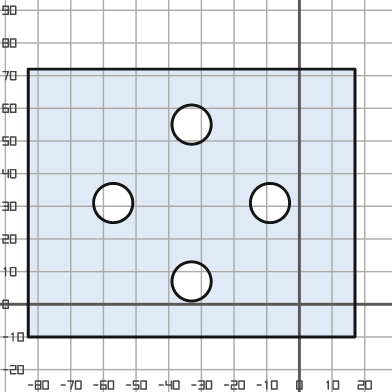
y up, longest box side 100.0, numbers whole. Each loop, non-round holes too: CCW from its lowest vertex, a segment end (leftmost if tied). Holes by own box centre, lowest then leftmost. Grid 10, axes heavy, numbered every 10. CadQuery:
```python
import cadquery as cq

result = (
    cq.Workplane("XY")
    .moveTo(-83.0, -10.0)
    .lineTo(17.0, -10.0)
    .lineTo(17.0, 72.0)
    .lineTo(-83.0, 72.0)
    .close()
    .moveTo(-33.0, 7.0)
    .circle(6.0)
    .moveTo(-57.0, 31.0)
    .circle(6.0)
    .moveTo(-9.0, 31.0)
    .circle(6.0)
    .moveTo(-33.0, 55.0)
    .circle(6.0)
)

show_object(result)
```